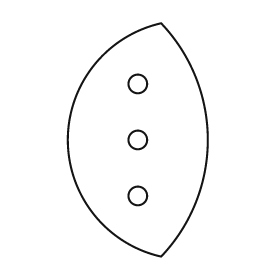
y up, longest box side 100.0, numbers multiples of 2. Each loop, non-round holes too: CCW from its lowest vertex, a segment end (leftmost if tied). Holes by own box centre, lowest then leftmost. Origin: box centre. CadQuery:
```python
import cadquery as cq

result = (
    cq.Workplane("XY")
    .moveTo(10.0, -50.0)
    .threePointArc((30.0, 0.0), (10.0, 50.0))
    .threePointArc((-30.0, 0.0), (10.0, -50.0))
    .close()
    .moveTo(0.0, -24.0)
    .circle(4.0)
    .moveTo(0.0, 0.0)
    .circle(4.0)
    .moveTo(0.0, 24.0)
    .circle(4.0)
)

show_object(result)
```